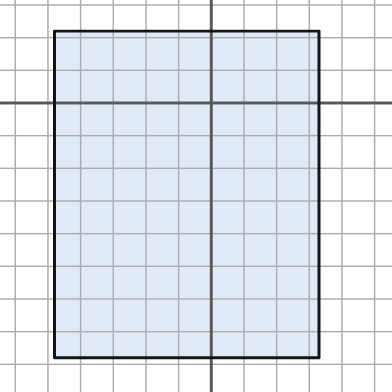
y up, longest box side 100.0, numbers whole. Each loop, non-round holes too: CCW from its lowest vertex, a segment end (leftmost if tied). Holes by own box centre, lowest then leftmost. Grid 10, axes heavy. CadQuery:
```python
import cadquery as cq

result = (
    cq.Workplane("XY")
    .moveTo(-48.0, -78.0)
    .lineTo(33.0, -78.0)
    .lineTo(33.0, 22.0)
    .lineTo(-48.0, 22.0)
    .close()
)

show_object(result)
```